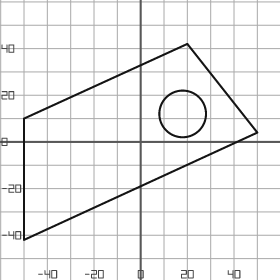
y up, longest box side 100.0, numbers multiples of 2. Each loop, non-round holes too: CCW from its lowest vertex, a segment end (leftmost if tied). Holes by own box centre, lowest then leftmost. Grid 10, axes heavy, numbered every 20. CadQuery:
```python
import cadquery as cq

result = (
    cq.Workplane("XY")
    .moveTo(-50.0, -42.0)
    .lineTo(50.0, 4.0)
    .lineTo(20.0, 42.0)
    .lineTo(-50.0, 10.0)
    .close()
    .moveTo(18.0, 12.0)
    .circle(10.0)
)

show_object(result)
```